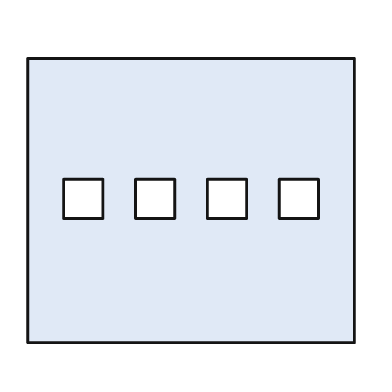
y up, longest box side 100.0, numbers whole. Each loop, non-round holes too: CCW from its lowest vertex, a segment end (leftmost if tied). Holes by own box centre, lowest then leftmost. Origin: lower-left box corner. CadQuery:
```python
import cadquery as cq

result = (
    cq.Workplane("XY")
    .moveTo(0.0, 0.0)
    .lineTo(100.0, 0.0)
    .lineTo(100.0, 87.0)
    .lineTo(0.0, 87.0)
    .close()
    .moveTo(11.0, 38.0)
    .lineTo(23.0, 38.0)
    .lineTo(23.0, 50.0)
    .lineTo(11.0, 50.0)
    .close()
    .moveTo(33.0, 38.0)
    .lineTo(45.0, 38.0)
    .lineTo(45.0, 50.0)
    .lineTo(33.0, 50.0)
    .close()
    .moveTo(55.0, 38.0)
    .lineTo(67.0, 38.0)
    .lineTo(67.0, 50.0)
    .lineTo(55.0, 50.0)
    .close()
    .moveTo(77.0, 38.0)
    .lineTo(89.0, 38.0)
    .lineTo(89.0, 50.0)
    .lineTo(77.0, 50.0)
    .close()
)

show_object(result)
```